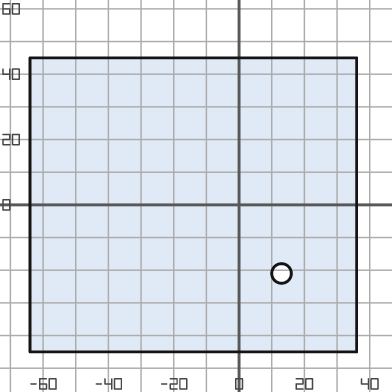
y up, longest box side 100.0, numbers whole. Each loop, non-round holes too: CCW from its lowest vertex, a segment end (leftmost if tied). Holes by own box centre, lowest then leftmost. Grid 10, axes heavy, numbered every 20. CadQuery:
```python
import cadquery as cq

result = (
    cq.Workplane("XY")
    .moveTo(-64.0, -45.0)
    .lineTo(36.0, -45.0)
    .lineTo(36.0, 45.0)
    .lineTo(-64.0, 45.0)
    .close()
    .moveTo(13.0, -21.0)
    .circle(3.0)
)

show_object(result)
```